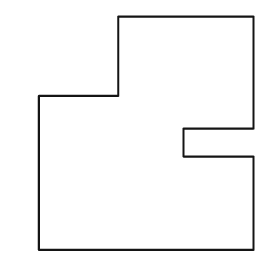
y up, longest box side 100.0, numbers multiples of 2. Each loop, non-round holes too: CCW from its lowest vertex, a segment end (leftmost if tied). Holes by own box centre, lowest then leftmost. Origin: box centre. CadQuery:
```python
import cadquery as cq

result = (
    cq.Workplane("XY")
    .moveTo(-46.0, -50.0)
    .lineTo(46.0, -50.0)
    .lineTo(46.0, -10.0)
    .lineTo(16.0, -10.0)
    .lineTo(16.0, 2.0)
    .lineTo(46.0, 2.0)
    .lineTo(46.0, 50.0)
    .lineTo(-12.0, 50.0)
    .lineTo(-12.0, 16.0)
    .lineTo(-46.0, 16.0)
    .close()
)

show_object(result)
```